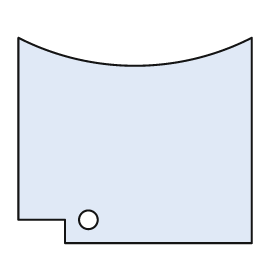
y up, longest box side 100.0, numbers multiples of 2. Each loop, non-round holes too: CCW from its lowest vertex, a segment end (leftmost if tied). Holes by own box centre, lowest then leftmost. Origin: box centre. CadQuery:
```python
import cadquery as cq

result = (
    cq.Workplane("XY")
    .moveTo(-30.0, -44.0)
    .lineTo(50.0, -44.0)
    .lineTo(50.0, 44.0)
    .threePointArc((0.0, 32.0), (-50.0, 44.0))
    .lineTo(-50.0, -34.0)
    .lineTo(-30.0, -34.0)
    .close()
    .moveTo(-20.0, -34.0)
    .circle(4.0)
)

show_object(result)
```